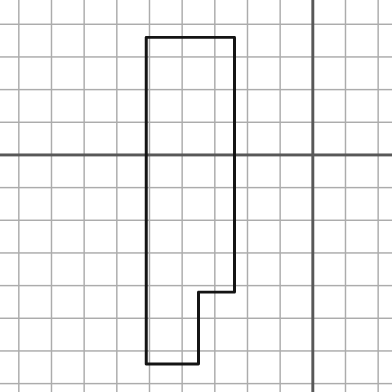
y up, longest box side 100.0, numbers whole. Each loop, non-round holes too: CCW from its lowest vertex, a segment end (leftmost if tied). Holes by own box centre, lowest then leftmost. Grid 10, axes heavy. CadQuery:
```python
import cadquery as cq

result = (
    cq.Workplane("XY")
    .moveTo(-51.0, -64.0)
    .lineTo(-35.0, -64.0)
    .lineTo(-35.0, -42.0)
    .lineTo(-24.0, -42.0)
    .lineTo(-24.0, 36.0)
    .lineTo(-51.0, 36.0)
    .close()
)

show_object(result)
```